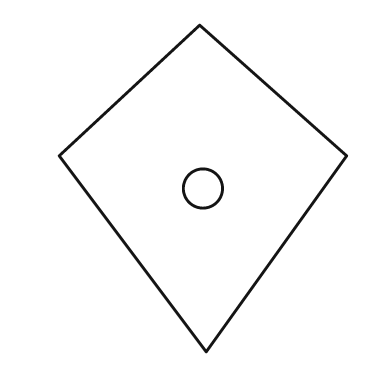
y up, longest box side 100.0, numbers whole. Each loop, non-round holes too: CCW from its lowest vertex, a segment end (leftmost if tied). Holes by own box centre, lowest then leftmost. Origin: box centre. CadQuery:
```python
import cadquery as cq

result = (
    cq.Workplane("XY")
    .moveTo(1.0, -50.0)
    .lineTo(44.0, 10.0)
    .lineTo(-1.0, 50.0)
    .lineTo(-44.0, 10.0)
    .close()
    .moveTo(0.0, 0.0)
    .circle(6.0)
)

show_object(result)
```